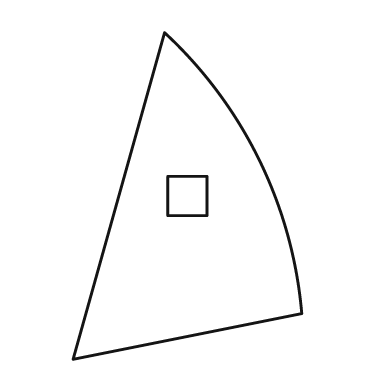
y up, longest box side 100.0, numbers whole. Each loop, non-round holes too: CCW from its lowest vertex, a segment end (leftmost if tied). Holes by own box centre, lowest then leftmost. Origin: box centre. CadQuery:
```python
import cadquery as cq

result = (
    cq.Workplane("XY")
    .moveTo(-35.0, -50.0)
    .lineTo(35.0, -36.0)
    .threePointArc((22.0, 11.0), (-7.0, 50.0))
    .close()
    .moveTo(-6.0, -6.0)
    .lineTo(6.0, -6.0)
    .lineTo(6.0, 6.0)
    .lineTo(-6.0, 6.0)
    .close()
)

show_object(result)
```